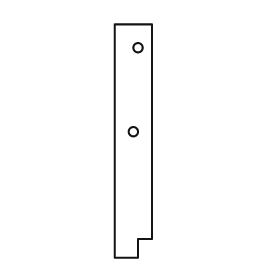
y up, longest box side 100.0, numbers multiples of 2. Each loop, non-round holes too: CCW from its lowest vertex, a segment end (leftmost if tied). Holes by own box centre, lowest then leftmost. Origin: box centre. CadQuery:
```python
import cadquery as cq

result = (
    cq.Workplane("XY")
    .moveTo(-8.0, -50.0)
    .lineTo(2.0, -50.0)
    .lineTo(2.0, -42.0)
    .lineTo(8.0, -42.0)
    .lineTo(8.0, 50.0)
    .lineTo(-8.0, 50.0)
    .close()
    .moveTo(0.0, 4.0)
    .circle(2.0)
    .moveTo(2.0, 40.0)
    .circle(2.0)
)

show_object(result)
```